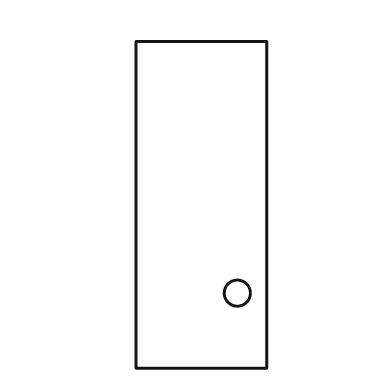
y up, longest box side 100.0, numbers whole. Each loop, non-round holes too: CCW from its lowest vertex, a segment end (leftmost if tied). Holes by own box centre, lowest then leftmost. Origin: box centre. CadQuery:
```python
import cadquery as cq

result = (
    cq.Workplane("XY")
    .moveTo(-20.0, -50.0)
    .lineTo(20.0, -50.0)
    .lineTo(20.0, 50.0)
    .lineTo(-20.0, 50.0)
    .close()
    .moveTo(11.0, -27.0)
    .circle(4.0)
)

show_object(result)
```